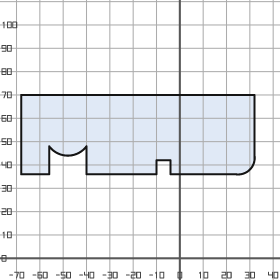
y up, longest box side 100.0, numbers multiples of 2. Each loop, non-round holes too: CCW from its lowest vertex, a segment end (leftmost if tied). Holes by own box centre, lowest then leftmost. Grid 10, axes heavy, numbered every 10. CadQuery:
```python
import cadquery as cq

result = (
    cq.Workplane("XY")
    .moveTo(-68.0, 36.0)
    .lineTo(-56.0, 36.0)
    .lineTo(-56.0, 48.0)
    .threePointArc((-48.0, 44.0), (-40.0, 48.0))
    .lineTo(-40.0, 36.0)
    .lineTo(-10.0, 36.0)
    .lineTo(-10.0, 42.0)
    .lineTo(-4.0, 42.0)
    .lineTo(-4.0, 36.0)
    .lineTo(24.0, 36.0)
    .threePointArc((30.0, 38.0), (32.0, 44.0))
    .lineTo(32.0, 70.0)
    .lineTo(-68.0, 70.0)
    .close()
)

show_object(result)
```